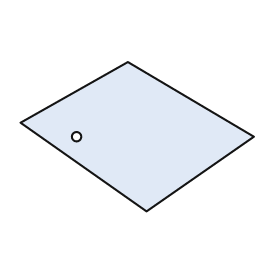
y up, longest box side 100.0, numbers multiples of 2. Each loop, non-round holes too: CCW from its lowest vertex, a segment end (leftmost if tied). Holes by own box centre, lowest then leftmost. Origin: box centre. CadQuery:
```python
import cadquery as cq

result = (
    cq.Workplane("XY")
    .moveTo(4.0, -32.0)
    .lineTo(50.0, 0.0)
    .lineTo(-4.0, 32.0)
    .lineTo(-50.0, 6.0)
    .close()
    .moveTo(-26.0, 0.0)
    .circle(2.0)
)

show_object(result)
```